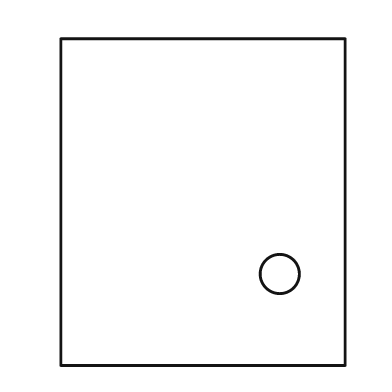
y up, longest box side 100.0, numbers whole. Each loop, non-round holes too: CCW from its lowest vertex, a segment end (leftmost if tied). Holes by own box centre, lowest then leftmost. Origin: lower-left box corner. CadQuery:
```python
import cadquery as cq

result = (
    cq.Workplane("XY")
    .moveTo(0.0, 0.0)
    .lineTo(87.0, 0.0)
    .lineTo(87.0, 100.0)
    .lineTo(0.0, 100.0)
    .close()
    .moveTo(67.0, 28.0)
    .circle(6.0)
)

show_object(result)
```